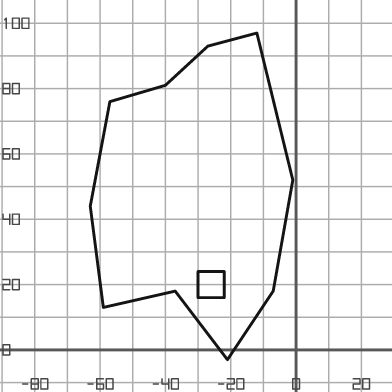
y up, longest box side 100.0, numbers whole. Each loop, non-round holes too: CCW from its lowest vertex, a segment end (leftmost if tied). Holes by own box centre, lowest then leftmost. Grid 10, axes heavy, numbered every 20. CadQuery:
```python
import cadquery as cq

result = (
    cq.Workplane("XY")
    .moveTo(-21.0, -3.0)
    .lineTo(-7.0, 18.0)
    .lineTo(-1.0, 52.0)
    .lineTo(-12.0, 97.0)
    .lineTo(-27.0, 93.0)
    .lineTo(-40.0, 81.0)
    .lineTo(-57.0, 76.0)
    .lineTo(-63.0, 44.0)
    .lineTo(-59.0, 13.0)
    .lineTo(-37.0, 18.0)
    .close()
    .moveTo(-30.0, 16.0)
    .lineTo(-22.0, 16.0)
    .lineTo(-22.0, 24.0)
    .lineTo(-30.0, 24.0)
    .close()
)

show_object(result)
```